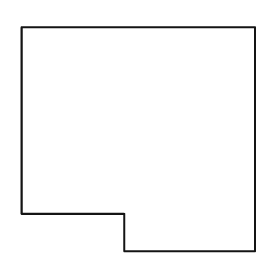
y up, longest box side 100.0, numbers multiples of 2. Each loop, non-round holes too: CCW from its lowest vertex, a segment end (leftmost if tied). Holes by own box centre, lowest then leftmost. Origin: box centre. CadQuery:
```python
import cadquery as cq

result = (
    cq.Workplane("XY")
    .moveTo(-6.0, -48.0)
    .lineTo(50.0, -48.0)
    .lineTo(50.0, 48.0)
    .lineTo(-50.0, 48.0)
    .lineTo(-50.0, -32.0)
    .lineTo(-6.0, -32.0)
    .close()
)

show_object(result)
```